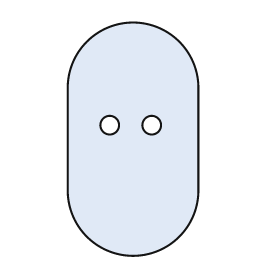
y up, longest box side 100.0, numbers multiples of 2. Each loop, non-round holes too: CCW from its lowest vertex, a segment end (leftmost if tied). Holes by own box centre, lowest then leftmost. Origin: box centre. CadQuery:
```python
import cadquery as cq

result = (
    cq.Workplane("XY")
    .moveTo(-28.0, -22.0)
    .threePointArc((0.0, -50.0), (28.0, -22.0))
    .lineTo(28.0, 22.0)
    .threePointArc((0.0, 50.0), (-28.0, 22.0))
    .close()
    .moveTo(-10.0, 6.0)
    .circle(4.0)
    .moveTo(8.0, 6.0)
    .circle(4.0)
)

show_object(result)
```